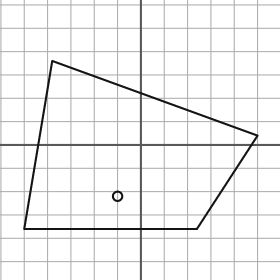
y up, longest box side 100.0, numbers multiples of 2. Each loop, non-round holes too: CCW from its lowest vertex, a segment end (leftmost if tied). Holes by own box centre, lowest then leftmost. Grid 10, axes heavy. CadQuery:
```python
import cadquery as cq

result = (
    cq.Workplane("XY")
    .moveTo(-50.0, -36.0)
    .lineTo(24.0, -36.0)
    .lineTo(50.0, 4.0)
    .lineTo(-38.0, 36.0)
    .close()
    .moveTo(-10.0, -22.0)
    .circle(2.0)
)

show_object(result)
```